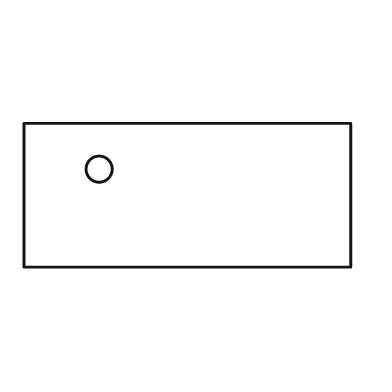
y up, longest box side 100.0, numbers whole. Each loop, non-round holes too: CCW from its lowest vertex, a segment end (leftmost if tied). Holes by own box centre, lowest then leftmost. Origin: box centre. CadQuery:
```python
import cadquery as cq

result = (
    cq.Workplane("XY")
    .moveTo(-50.0, -22.0)
    .lineTo(50.0, -22.0)
    .lineTo(50.0, 22.0)
    .lineTo(-50.0, 22.0)
    .close()
    .moveTo(-27.0, 8.0)
    .circle(4.0)
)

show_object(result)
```